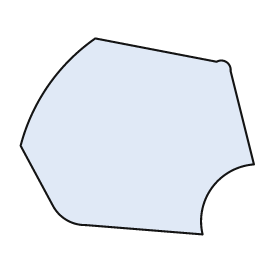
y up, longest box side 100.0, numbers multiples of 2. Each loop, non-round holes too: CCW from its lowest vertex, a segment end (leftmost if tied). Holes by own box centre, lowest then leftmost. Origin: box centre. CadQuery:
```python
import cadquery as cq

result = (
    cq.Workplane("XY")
    .moveTo(28.0, -42.0)
    .threePointArc((32.0, -22.0), (50.0, -12.0))
    .lineTo(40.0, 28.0)
    .threePointArc((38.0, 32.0), (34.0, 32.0))
    .lineTo(-18.0, 42.0)
    .threePointArc((-38.0, 22.0), (-50.0, -4.0))
    .lineTo(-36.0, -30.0)
    .threePointArc((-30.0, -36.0), (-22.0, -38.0))
    .close()
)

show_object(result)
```